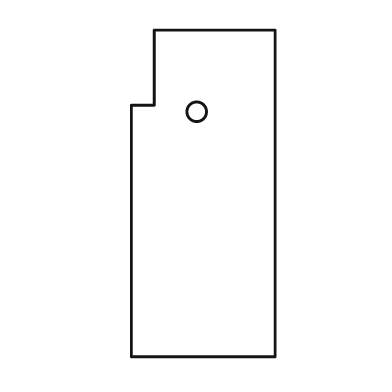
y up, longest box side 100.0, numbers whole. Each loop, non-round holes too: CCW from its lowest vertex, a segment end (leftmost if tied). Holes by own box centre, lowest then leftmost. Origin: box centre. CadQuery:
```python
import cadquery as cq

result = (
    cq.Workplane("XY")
    .moveTo(-22.0, -50.0)
    .lineTo(22.0, -50.0)
    .lineTo(22.0, 50.0)
    .lineTo(-15.0, 50.0)
    .lineTo(-15.0, 27.0)
    .lineTo(-22.0, 27.0)
    .close()
    .moveTo(-2.0, 25.0)
    .circle(3.0)
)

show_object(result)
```